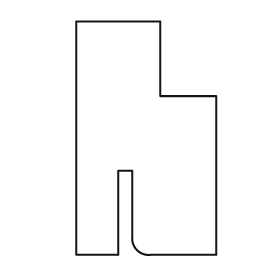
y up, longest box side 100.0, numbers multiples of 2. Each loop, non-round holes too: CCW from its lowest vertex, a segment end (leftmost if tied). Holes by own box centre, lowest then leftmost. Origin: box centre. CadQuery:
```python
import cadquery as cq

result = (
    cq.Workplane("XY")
    .moveTo(-30.0, -50.0)
    .lineTo(-12.0, -50.0)
    .lineTo(-12.0, -14.0)
    .lineTo(-6.0, -14.0)
    .lineTo(-6.0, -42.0)
    .threePointArc((-4.0, -48.0), (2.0, -50.0))
    .lineTo(30.0, -50.0)
    .lineTo(30.0, 18.0)
    .lineTo(6.0, 18.0)
    .lineTo(6.0, 50.0)
    .lineTo(-30.0, 50.0)
    .close()
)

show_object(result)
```